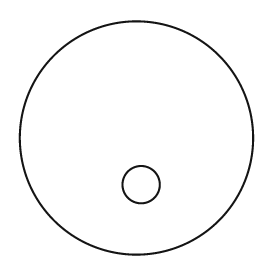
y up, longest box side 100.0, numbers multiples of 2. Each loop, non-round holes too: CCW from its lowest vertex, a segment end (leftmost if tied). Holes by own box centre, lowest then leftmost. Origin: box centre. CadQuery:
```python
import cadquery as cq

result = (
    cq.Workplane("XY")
    .moveTo(0.0, 0.0)
    .circle(50.0)
    .moveTo(2.0, -20.0)
    .circle(8.0)
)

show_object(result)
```